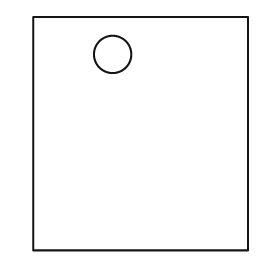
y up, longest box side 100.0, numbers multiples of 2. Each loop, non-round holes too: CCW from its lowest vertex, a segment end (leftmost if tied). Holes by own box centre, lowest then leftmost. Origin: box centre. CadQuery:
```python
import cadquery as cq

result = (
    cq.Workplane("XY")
    .moveTo(-46.0, -50.0)
    .lineTo(46.0, -50.0)
    .lineTo(46.0, 50.0)
    .lineTo(-46.0, 50.0)
    .close()
    .moveTo(-12.0, 34.0)
    .circle(8.0)
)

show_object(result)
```